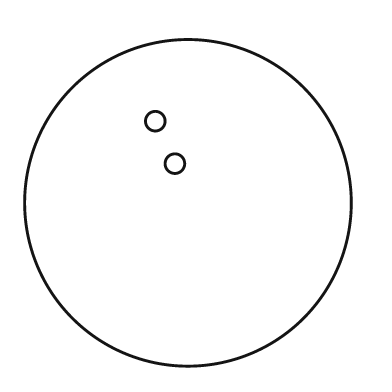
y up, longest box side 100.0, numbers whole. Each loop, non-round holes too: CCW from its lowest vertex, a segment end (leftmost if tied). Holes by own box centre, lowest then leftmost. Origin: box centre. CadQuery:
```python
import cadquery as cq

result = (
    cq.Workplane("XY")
    .moveTo(0.0, 0.0)
    .circle(50.0)
    .moveTo(-4.0, 12.0)
    .circle(3.0)
    .moveTo(-10.0, 25.0)
    .circle(3.0)
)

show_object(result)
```